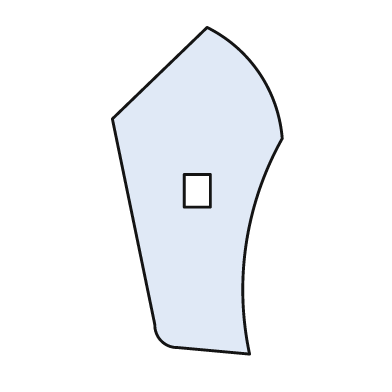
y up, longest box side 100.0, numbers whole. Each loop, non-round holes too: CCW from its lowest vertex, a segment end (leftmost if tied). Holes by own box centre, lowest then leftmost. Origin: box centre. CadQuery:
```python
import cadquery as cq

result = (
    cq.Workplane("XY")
    .moveTo(16.0, -50.0)
    .threePointArc((15.0, -16.0), (26.0, 16.0))
    .threePointArc((19.0, 36.0), (3.0, 50.0))
    .lineTo(-26.0, 22.0)
    .lineTo(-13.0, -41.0)
    .threePointArc((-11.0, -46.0), (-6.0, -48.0))
    .close()
    .moveTo(-4.0, -5.0)
    .lineTo(4.0, -5.0)
    .lineTo(4.0, 5.0)
    .lineTo(-4.0, 5.0)
    .close()
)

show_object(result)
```